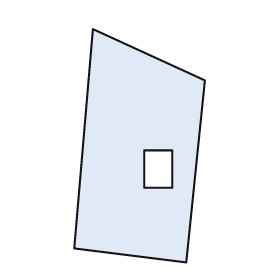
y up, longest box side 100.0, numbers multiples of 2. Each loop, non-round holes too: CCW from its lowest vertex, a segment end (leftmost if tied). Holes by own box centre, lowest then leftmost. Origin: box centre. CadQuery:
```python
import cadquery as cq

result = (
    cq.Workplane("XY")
    .moveTo(20.0, -50.0)
    .lineTo(28.0, 28.0)
    .lineTo(-20.0, 50.0)
    .lineTo(-28.0, -44.0)
    .close()
    .moveTo(2.0, -18.0)
    .lineTo(14.0, -18.0)
    .lineTo(14.0, -2.0)
    .lineTo(2.0, -2.0)
    .close()
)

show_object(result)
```